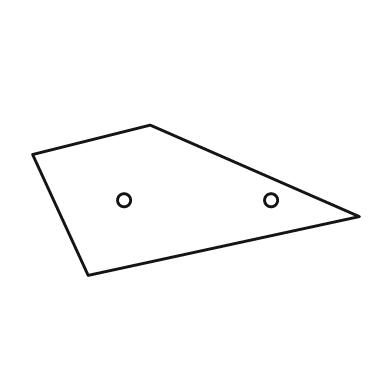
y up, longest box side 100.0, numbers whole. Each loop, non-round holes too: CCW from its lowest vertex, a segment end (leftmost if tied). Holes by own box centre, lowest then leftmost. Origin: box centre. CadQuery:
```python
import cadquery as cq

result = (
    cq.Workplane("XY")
    .moveTo(-33.0, -23.0)
    .lineTo(50.0, -5.0)
    .lineTo(-14.0, 23.0)
    .lineTo(-50.0, 14.0)
    .close()
    .moveTo(-22.0, 0.0)
    .circle(2.0)
    .moveTo(23.0, 0.0)
    .circle(2.0)
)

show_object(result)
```